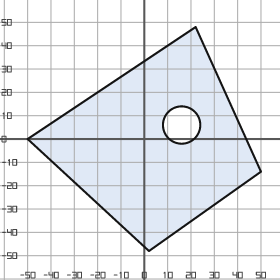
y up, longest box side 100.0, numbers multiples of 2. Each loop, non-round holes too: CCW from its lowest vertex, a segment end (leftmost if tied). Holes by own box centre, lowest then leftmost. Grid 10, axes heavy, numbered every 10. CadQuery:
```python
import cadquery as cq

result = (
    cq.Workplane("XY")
    .moveTo(2.0, -48.0)
    .lineTo(50.0, -14.0)
    .lineTo(22.0, 48.0)
    .lineTo(-50.0, 0.0)
    .close()
    .moveTo(16.0, 6.0)
    .circle(8.0)
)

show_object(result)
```